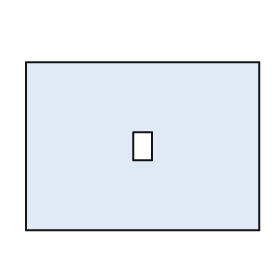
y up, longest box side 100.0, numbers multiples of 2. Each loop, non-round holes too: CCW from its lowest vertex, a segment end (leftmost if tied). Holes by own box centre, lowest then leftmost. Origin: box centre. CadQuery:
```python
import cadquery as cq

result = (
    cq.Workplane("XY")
    .moveTo(-50.0, -36.0)
    .lineTo(50.0, -36.0)
    .lineTo(50.0, 36.0)
    .lineTo(-50.0, 36.0)
    .close()
    .moveTo(-4.0, -6.0)
    .lineTo(4.0, -6.0)
    .lineTo(4.0, 6.0)
    .lineTo(-4.0, 6.0)
    .close()
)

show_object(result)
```